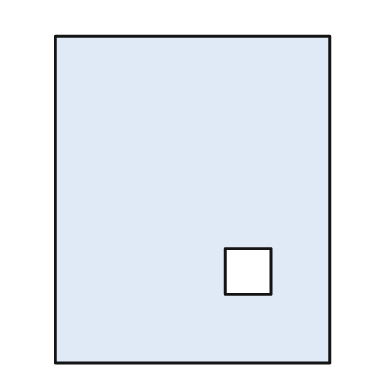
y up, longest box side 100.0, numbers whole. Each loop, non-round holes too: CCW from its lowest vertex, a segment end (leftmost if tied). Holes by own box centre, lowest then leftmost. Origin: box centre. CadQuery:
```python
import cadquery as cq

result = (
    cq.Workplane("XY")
    .moveTo(-42.0, -50.0)
    .lineTo(42.0, -50.0)
    .lineTo(42.0, 50.0)
    .lineTo(-42.0, 50.0)
    .close()
    .moveTo(10.0, -29.0)
    .lineTo(24.0, -29.0)
    .lineTo(24.0, -15.0)
    .lineTo(10.0, -15.0)
    .close()
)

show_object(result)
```